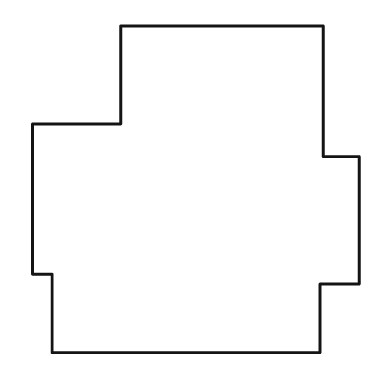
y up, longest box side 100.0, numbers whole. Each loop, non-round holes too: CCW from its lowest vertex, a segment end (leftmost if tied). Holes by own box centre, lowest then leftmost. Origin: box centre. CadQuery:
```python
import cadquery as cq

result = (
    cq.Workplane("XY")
    .moveTo(-44.0, -50.0)
    .lineTo(38.0, -50.0)
    .lineTo(38.0, -29.0)
    .lineTo(50.0, -29.0)
    .lineTo(50.0, 10.0)
    .lineTo(39.0, 10.0)
    .lineTo(39.0, 50.0)
    .lineTo(-23.0, 50.0)
    .lineTo(-23.0, 20.0)
    .lineTo(-50.0, 20.0)
    .lineTo(-50.0, -26.0)
    .lineTo(-44.0, -26.0)
    .close()
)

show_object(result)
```